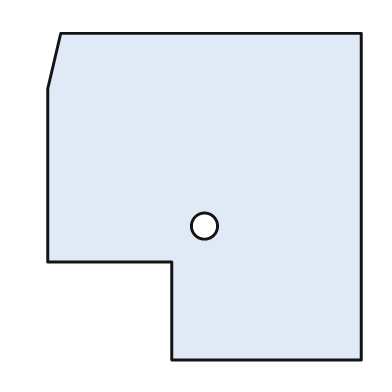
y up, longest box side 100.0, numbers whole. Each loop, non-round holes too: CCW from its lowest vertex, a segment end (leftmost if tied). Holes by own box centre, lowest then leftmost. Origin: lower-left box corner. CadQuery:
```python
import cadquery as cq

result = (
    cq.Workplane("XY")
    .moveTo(38.0, 0.0)
    .lineTo(96.0, 0.0)
    .lineTo(96.0, 100.0)
    .lineTo(4.0, 100.0)
    .lineTo(0.0, 83.0)
    .lineTo(0.0, 30.0)
    .lineTo(38.0, 30.0)
    .close()
    .moveTo(48.0, 41.0)
    .circle(4.0)
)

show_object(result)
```